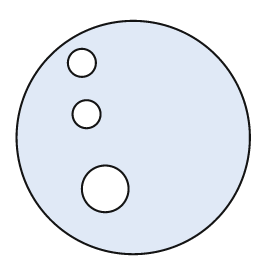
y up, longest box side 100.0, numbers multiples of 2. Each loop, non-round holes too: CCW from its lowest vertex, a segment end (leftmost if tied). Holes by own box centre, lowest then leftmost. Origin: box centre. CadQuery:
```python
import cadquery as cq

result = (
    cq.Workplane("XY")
    .moveTo(0.0, 0.0)
    .circle(50.0)
    .moveTo(-12.0, -22.0)
    .circle(10.0)
    .moveTo(-20.0, 10.0)
    .circle(6.0)
    .moveTo(-22.0, 32.0)
    .circle(6.0)
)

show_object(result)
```